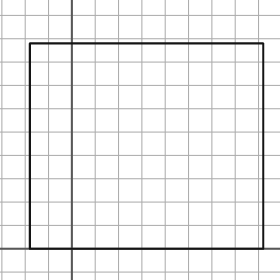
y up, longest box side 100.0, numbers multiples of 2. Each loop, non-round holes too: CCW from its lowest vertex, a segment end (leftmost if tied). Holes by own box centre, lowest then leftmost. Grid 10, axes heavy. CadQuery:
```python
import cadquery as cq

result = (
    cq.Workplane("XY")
    .moveTo(-18.0, 0.0)
    .lineTo(82.0, 0.0)
    .lineTo(82.0, 88.0)
    .lineTo(-18.0, 88.0)
    .close()
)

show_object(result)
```